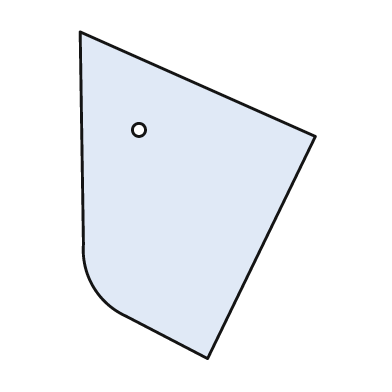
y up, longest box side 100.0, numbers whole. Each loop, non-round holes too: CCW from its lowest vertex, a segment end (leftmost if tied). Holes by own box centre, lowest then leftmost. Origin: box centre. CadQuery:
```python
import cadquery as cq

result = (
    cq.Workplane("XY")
    .moveTo(3.0, -50.0)
    .lineTo(36.0, 18.0)
    .lineTo(-36.0, 50.0)
    .lineTo(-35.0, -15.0)
    .threePointArc((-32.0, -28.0), (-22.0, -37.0))
    .close()
    .moveTo(-18.0, 20.0)
    .circle(2.0)
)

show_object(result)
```